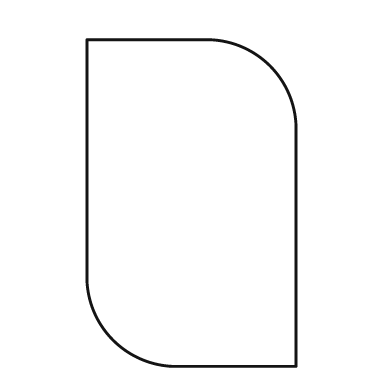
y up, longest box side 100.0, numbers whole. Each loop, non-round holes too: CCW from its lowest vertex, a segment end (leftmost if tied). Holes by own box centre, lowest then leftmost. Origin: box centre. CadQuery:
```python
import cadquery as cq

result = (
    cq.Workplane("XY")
    .moveTo(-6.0, -50.0)
    .lineTo(32.0, -50.0)
    .lineTo(32.0, 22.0)
    .threePointArc((24.0, 42.0), (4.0, 50.0))
    .lineTo(-32.0, 50.0)
    .lineTo(-32.0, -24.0)
    .threePointArc((-24.0, -42.0), (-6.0, -50.0))
    .close()
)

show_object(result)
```